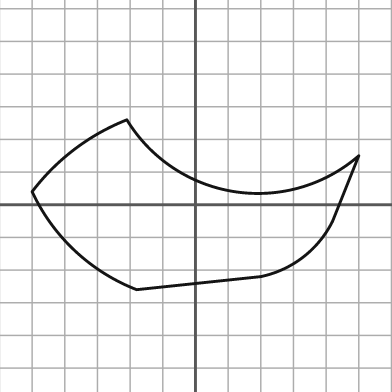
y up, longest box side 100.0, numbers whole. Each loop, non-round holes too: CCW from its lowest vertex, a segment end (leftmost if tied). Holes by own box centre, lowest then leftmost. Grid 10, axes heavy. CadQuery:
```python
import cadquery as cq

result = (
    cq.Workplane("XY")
    .moveTo(-18.0, -26.0)
    .lineTo(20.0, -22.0)
    .threePointArc((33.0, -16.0), (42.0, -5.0))
    .lineTo(50.0, 15.0)
    .threePointArc((12.0, 4.0), (-21.0, 26.0))
    .threePointArc((-37.0, 17.0), (-50.0, 4.0))
    .threePointArc((-37.0, -14.0), (-18.0, -26.0))
    .close()
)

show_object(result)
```